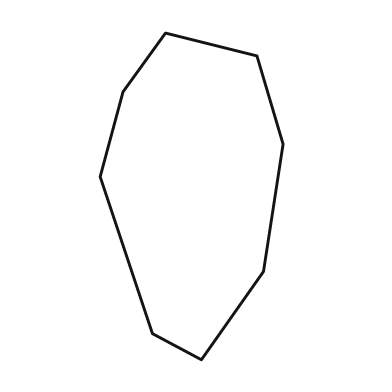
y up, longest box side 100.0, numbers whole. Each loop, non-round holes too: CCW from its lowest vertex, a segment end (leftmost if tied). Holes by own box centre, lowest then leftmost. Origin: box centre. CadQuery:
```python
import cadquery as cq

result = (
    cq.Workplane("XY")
    .moveTo(3.0, -50.0)
    .lineTo(22.0, -23.0)
    .lineTo(28.0, 16.0)
    .lineTo(20.0, 43.0)
    .lineTo(-8.0, 50.0)
    .lineTo(-21.0, 32.0)
    .lineTo(-28.0, 6.0)
    .lineTo(-12.0, -42.0)
    .close()
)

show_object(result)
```